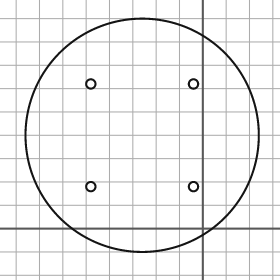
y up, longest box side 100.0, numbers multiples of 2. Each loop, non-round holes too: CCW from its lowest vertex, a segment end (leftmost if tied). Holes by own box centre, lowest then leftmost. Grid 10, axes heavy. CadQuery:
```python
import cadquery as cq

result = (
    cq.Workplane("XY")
    .moveTo(-26.0, 40.0)
    .circle(50.0)
    .moveTo(-48.0, 18.0)
    .circle(2.0)
    .moveTo(-4.0, 18.0)
    .circle(2.0)
    .moveTo(-48.0, 62.0)
    .circle(2.0)
    .moveTo(-4.0, 62.0)
    .circle(2.0)
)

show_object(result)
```